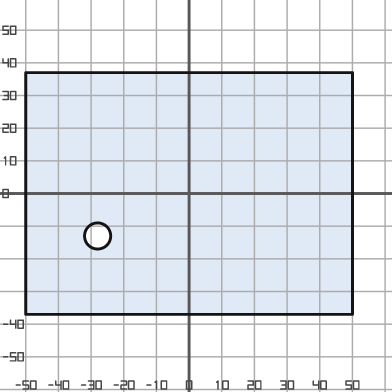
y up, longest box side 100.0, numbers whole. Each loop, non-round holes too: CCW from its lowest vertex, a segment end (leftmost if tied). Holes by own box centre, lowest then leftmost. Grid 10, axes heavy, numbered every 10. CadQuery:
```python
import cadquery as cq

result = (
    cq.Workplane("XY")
    .moveTo(-50.0, -37.0)
    .lineTo(50.0, -37.0)
    .lineTo(50.0, 37.0)
    .lineTo(-50.0, 37.0)
    .close()
    .moveTo(-28.0, -13.0)
    .circle(4.0)
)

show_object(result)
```